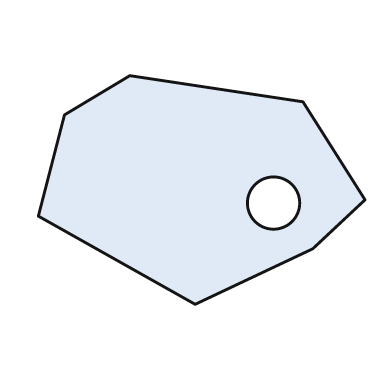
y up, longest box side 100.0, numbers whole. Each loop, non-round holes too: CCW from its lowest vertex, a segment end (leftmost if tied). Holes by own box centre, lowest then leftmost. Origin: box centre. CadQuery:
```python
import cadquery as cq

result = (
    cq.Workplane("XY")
    .moveTo(-2.0, -35.0)
    .lineTo(34.0, -18.0)
    .lineTo(50.0, -3.0)
    .lineTo(31.0, 27.0)
    .lineTo(-22.0, 35.0)
    .lineTo(-42.0, 23.0)
    .lineTo(-50.0, -8.0)
    .close()
    .moveTo(22.0, -4.0)
    .circle(8.0)
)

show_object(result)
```